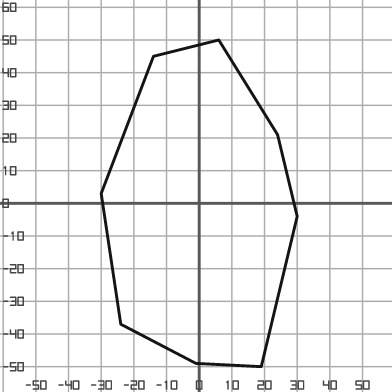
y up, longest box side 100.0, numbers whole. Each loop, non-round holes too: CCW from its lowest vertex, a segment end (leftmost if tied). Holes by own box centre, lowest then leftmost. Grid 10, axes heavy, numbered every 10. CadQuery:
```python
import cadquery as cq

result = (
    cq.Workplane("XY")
    .moveTo(19.0, -50.0)
    .lineTo(30.0, -4.0)
    .lineTo(24.0, 21.0)
    .lineTo(6.0, 50.0)
    .lineTo(-14.0, 45.0)
    .lineTo(-30.0, 3.0)
    .lineTo(-24.0, -37.0)
    .lineTo(-1.0, -49.0)
    .close()
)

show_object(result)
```